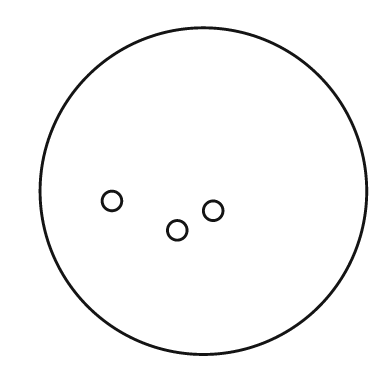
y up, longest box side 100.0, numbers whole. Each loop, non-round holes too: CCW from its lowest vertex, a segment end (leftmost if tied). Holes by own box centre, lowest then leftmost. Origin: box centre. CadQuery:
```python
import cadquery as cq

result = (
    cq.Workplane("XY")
    .moveTo(0.0, 0.0)
    .circle(50.0)
    .moveTo(-8.0, -12.0)
    .circle(3.0)
    .moveTo(3.0, -6.0)
    .circle(3.0)
    .moveTo(-28.0, -3.0)
    .circle(3.0)
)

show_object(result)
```